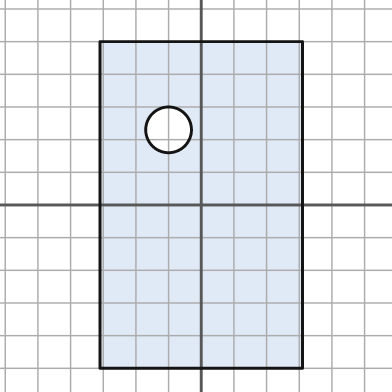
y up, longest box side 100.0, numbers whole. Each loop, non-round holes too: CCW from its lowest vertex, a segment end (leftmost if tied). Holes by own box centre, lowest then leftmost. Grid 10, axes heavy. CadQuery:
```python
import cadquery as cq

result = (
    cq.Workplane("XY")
    .moveTo(-31.0, -50.0)
    .lineTo(31.0, -50.0)
    .lineTo(31.0, 50.0)
    .lineTo(-31.0, 50.0)
    .close()
    .moveTo(-10.0, 23.0)
    .circle(7.0)
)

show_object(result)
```